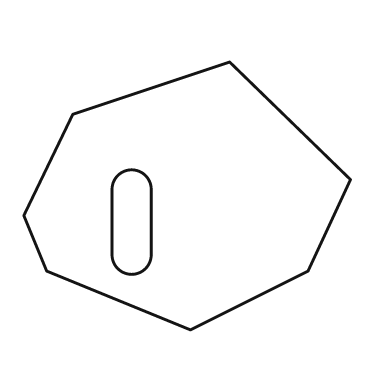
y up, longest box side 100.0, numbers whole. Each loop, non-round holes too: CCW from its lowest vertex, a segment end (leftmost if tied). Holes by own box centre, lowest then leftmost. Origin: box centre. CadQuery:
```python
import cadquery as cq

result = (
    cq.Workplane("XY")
    .moveTo(1.0, -41.0)
    .lineTo(37.0, -23.0)
    .lineTo(50.0, 5.0)
    .lineTo(13.0, 41.0)
    .lineTo(-35.0, 25.0)
    .lineTo(-50.0, -6.0)
    .lineTo(-43.0, -23.0)
    .close()
    .moveTo(-23.0, -18.0)
    .threePointArc((-17.0, -24.0), (-11.0, -18.0))
    .lineTo(-11.0, 2.0)
    .threePointArc((-17.0, 8.0), (-23.0, 2.0))
    .close()
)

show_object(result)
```